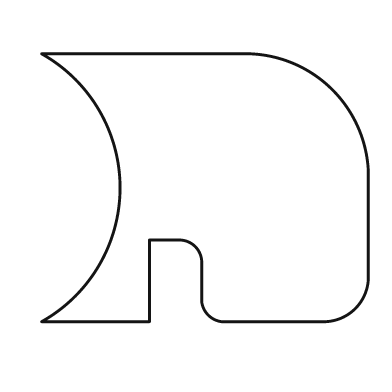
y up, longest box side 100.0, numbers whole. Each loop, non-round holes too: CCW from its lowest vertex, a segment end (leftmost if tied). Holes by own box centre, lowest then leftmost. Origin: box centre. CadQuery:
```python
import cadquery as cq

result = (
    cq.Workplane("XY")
    .moveTo(-50.0, -41.0)
    .lineTo(-17.0, -41.0)
    .lineTo(-17.0, -16.0)
    .lineTo(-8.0, -16.0)
    .threePointArc((-3.0, -18.0), (-1.0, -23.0))
    .lineTo(-1.0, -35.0)
    .threePointArc((1.0, -39.0), (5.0, -41.0))
    .lineTo(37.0, -41.0)
    .threePointArc((46.0, -37.0), (50.0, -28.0))
    .lineTo(50.0, 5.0)
    .threePointArc((39.0, 30.0), (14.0, 41.0))
    .lineTo(-50.0, 41.0)
    .threePointArc((-26.0, 0.0), (-50.0, -41.0))
    .close()
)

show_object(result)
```